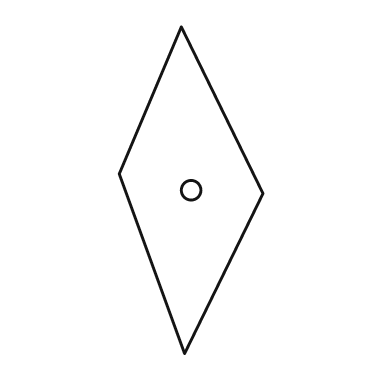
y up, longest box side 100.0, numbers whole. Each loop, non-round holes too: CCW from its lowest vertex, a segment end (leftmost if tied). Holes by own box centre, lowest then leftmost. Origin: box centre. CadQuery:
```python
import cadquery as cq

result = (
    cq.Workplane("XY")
    .moveTo(-2.0, -50.0)
    .lineTo(22.0, -1.0)
    .lineTo(-3.0, 50.0)
    .lineTo(-22.0, 5.0)
    .close()
    .moveTo(0.0, 0.0)
    .circle(3.0)
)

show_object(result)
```